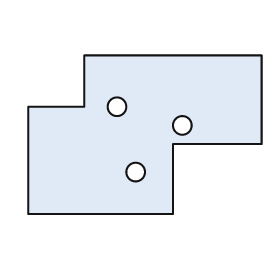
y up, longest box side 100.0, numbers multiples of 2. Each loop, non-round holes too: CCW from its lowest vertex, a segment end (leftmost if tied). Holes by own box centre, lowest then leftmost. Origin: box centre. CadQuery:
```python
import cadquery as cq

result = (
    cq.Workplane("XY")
    .moveTo(-50.0, -34.0)
    .lineTo(12.0, -34.0)
    .lineTo(12.0, -4.0)
    .lineTo(50.0, -4.0)
    .lineTo(50.0, 34.0)
    .lineTo(-26.0, 34.0)
    .lineTo(-26.0, 12.0)
    .lineTo(-50.0, 12.0)
    .close()
    .moveTo(-4.0, -16.0)
    .circle(4.0)
    .moveTo(16.0, 4.0)
    .circle(4.0)
    .moveTo(-12.0, 12.0)
    .circle(4.0)
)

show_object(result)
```